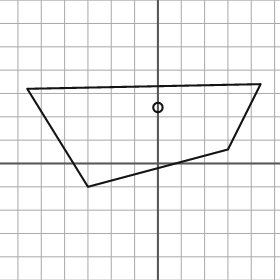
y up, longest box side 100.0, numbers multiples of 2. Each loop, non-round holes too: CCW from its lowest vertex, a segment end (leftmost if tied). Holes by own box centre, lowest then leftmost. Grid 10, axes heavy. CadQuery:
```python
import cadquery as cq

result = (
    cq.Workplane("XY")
    .moveTo(-30.0, -10.0)
    .lineTo(30.0, 6.0)
    .lineTo(44.0, 34.0)
    .lineTo(-56.0, 32.0)
    .close()
    .moveTo(0.0, 24.0)
    .circle(2.0)
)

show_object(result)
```